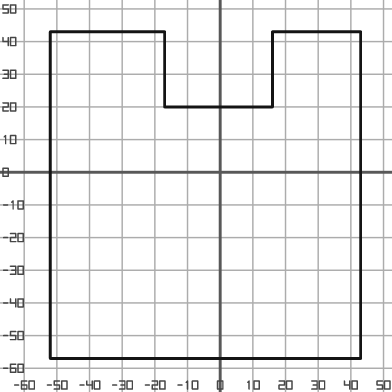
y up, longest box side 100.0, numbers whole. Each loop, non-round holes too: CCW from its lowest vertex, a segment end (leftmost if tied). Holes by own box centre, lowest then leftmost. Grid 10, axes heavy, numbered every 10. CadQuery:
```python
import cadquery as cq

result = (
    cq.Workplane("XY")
    .moveTo(-52.0, -57.0)
    .lineTo(43.0, -57.0)
    .lineTo(43.0, 43.0)
    .lineTo(16.0, 43.0)
    .lineTo(16.0, 20.0)
    .lineTo(-17.0, 20.0)
    .lineTo(-17.0, 43.0)
    .lineTo(-52.0, 43.0)
    .close()
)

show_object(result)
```